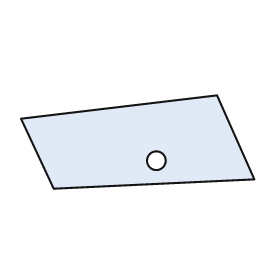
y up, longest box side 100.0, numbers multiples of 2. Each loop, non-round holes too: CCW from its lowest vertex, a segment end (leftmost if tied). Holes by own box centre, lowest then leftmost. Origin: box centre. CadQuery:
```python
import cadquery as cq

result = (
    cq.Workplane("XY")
    .moveTo(-36.0, -20.0)
    .lineTo(50.0, -16.0)
    .lineTo(34.0, 20.0)
    .lineTo(-50.0, 10.0)
    .close()
    .moveTo(8.0, -8.0)
    .circle(4.0)
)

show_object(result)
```